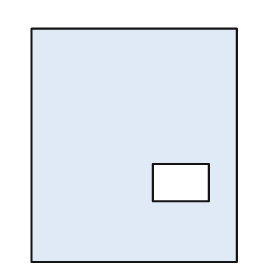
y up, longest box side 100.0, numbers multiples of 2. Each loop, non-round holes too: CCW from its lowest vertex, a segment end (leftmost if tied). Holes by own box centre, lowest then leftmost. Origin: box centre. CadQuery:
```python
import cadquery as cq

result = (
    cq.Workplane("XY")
    .moveTo(-44.0, -50.0)
    .lineTo(44.0, -50.0)
    .lineTo(44.0, 50.0)
    .lineTo(-44.0, 50.0)
    .close()
    .moveTo(8.0, -24.0)
    .lineTo(32.0, -24.0)
    .lineTo(32.0, -8.0)
    .lineTo(8.0, -8.0)
    .close()
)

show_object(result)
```